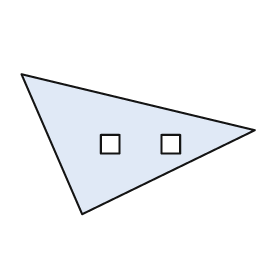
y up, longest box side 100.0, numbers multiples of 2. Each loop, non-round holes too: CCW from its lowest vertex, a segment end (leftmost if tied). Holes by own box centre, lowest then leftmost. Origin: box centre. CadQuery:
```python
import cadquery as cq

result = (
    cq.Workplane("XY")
    .moveTo(-24.0, -30.0)
    .lineTo(50.0, 6.0)
    .lineTo(-50.0, 30.0)
    .close()
    .moveTo(-16.0, -4.0)
    .lineTo(-8.0, -4.0)
    .lineTo(-8.0, 4.0)
    .lineTo(-16.0, 4.0)
    .close()
    .moveTo(10.0, -4.0)
    .lineTo(18.0, -4.0)
    .lineTo(18.0, 4.0)
    .lineTo(10.0, 4.0)
    .close()
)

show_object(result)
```